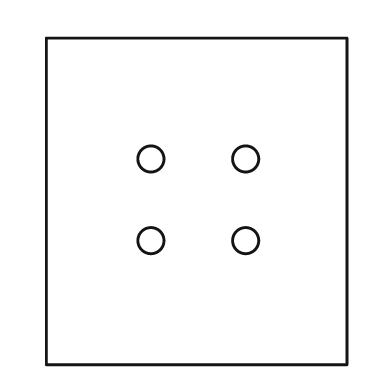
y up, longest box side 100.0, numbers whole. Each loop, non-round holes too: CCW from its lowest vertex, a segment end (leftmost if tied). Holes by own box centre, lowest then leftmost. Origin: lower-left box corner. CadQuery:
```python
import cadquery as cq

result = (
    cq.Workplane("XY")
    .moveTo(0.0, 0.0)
    .lineTo(92.0, 0.0)
    .lineTo(92.0, 100.0)
    .lineTo(0.0, 100.0)
    .close()
    .moveTo(32.0, 38.0)
    .circle(4.0)
    .moveTo(61.0, 38.0)
    .circle(4.0)
    .moveTo(32.0, 63.0)
    .circle(4.0)
    .moveTo(61.0, 63.0)
    .circle(4.0)
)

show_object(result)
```